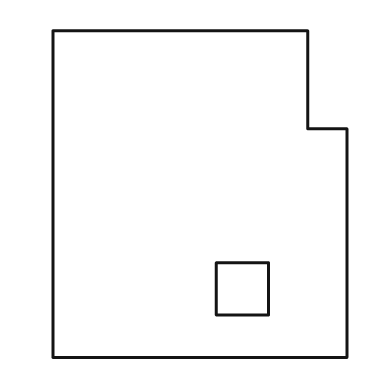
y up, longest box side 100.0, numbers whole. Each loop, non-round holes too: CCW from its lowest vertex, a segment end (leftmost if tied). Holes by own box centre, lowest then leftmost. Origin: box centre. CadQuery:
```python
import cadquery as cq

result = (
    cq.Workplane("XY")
    .moveTo(-45.0, -50.0)
    .lineTo(45.0, -50.0)
    .lineTo(45.0, 20.0)
    .lineTo(33.0, 20.0)
    .lineTo(33.0, 50.0)
    .lineTo(-45.0, 50.0)
    .close()
    .moveTo(5.0, -37.0)
    .lineTo(21.0, -37.0)
    .lineTo(21.0, -21.0)
    .lineTo(5.0, -21.0)
    .close()
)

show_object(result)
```